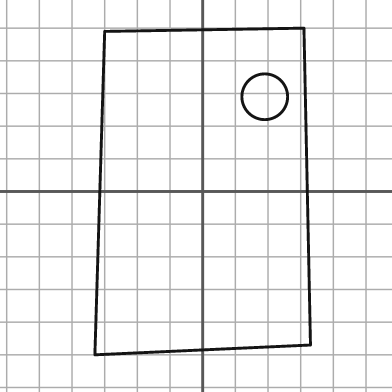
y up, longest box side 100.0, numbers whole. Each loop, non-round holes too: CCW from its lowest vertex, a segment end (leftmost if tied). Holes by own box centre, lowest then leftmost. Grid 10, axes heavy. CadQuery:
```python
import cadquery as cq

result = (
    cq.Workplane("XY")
    .moveTo(-33.0, -50.0)
    .lineTo(33.0, -47.0)
    .lineTo(31.0, 50.0)
    .lineTo(-30.0, 49.0)
    .close()
    .moveTo(19.0, 29.0)
    .circle(7.0)
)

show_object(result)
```